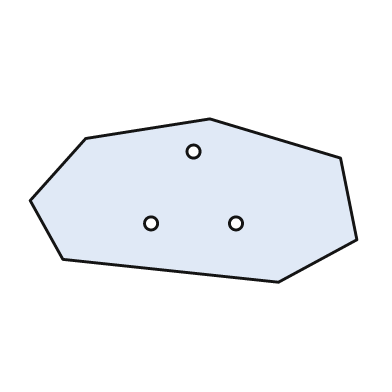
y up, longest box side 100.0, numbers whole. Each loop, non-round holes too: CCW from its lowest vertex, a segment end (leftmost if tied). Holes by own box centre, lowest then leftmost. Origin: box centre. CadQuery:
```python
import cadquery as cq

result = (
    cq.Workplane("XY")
    .moveTo(26.0, -25.0)
    .lineTo(50.0, -12.0)
    .lineTo(45.0, 13.0)
    .lineTo(5.0, 25.0)
    .lineTo(-33.0, 19.0)
    .lineTo(-50.0, 0.0)
    .lineTo(-40.0, -18.0)
    .close()
    .moveTo(-13.0, -7.0)
    .circle(2.0)
    .moveTo(13.0, -7.0)
    .circle(2.0)
    .moveTo(0.0, 15.0)
    .circle(2.0)
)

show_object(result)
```